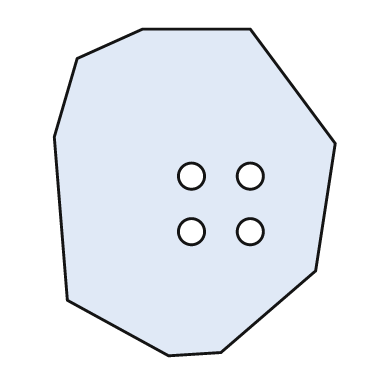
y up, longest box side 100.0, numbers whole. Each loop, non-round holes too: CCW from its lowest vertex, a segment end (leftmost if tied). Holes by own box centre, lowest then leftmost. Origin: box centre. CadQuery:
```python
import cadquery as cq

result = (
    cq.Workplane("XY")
    .moveTo(-8.0, -50.0)
    .lineTo(8.0, -49.0)
    .lineTo(37.0, -24.0)
    .lineTo(43.0, 15.0)
    .lineTo(17.0, 50.0)
    .lineTo(-16.0, 50.0)
    .lineTo(-36.0, 41.0)
    .lineTo(-43.0, 17.0)
    .lineTo(-39.0, -33.0)
    .close()
    .moveTo(-1.0, -12.0)
    .circle(4.0)
    .moveTo(17.0, -12.0)
    .circle(4.0)
    .moveTo(-1.0, 5.0)
    .circle(4.0)
    .moveTo(17.0, 5.0)
    .circle(4.0)
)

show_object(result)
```